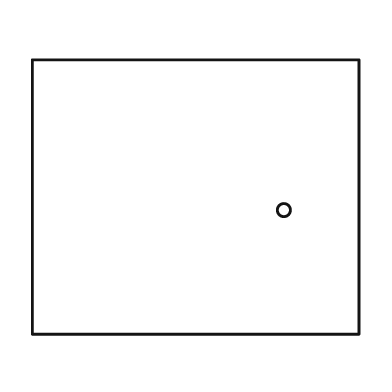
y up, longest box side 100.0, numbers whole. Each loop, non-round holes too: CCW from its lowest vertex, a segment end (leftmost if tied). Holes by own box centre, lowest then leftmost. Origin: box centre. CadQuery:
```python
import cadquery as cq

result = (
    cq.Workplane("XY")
    .moveTo(-50.0, -42.0)
    .lineTo(50.0, -42.0)
    .lineTo(50.0, 42.0)
    .lineTo(-50.0, 42.0)
    .close()
    .moveTo(27.0, -4.0)
    .circle(2.0)
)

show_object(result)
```